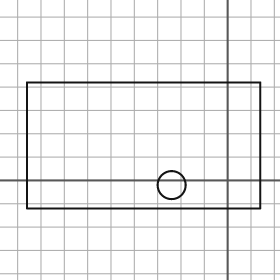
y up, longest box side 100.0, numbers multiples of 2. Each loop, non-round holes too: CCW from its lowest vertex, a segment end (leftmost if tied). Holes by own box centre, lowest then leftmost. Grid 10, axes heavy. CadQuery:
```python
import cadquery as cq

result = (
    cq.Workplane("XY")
    .moveTo(-86.0, -12.0)
    .lineTo(14.0, -12.0)
    .lineTo(14.0, 42.0)
    .lineTo(-86.0, 42.0)
    .close()
    .moveTo(-24.0, -2.0)
    .circle(6.0)
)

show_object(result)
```